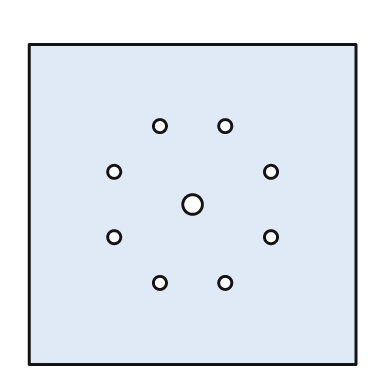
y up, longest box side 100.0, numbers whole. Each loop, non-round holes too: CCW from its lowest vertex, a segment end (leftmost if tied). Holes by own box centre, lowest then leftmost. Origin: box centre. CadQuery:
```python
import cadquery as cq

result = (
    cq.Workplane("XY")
    .moveTo(-50.0, -49.0)
    .lineTo(50.0, -49.0)
    .lineTo(50.0, 49.0)
    .lineTo(-50.0, 49.0)
    .close()
    .moveTo(-10.0, -24.0)
    .circle(2.0)
    .moveTo(10.0, -24.0)
    .circle(2.0)
    .moveTo(-24.0, -10.0)
    .circle(2.0)
    .moveTo(24.0, -10.0)
    .circle(2.0)
    .moveTo(0.0, 0.0)
    .circle(3.0)
    .moveTo(-24.0, 10.0)
    .circle(2.0)
    .moveTo(24.0, 10.0)
    .circle(2.0)
    .moveTo(-10.0, 24.0)
    .circle(2.0)
    .moveTo(10.0, 24.0)
    .circle(2.0)
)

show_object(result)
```